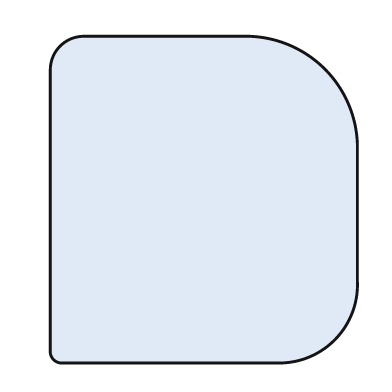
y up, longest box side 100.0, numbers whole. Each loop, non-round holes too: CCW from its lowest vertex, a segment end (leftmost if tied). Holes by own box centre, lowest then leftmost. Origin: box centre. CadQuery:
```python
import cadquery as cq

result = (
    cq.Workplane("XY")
    .moveTo(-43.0, -50.0)
    .lineTo(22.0, -50.0)
    .threePointArc((40.0, -43.0), (47.0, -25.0))
    .lineTo(47.0, 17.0)
    .threePointArc((37.0, 40.0), (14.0, 50.0))
    .lineTo(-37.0, 50.0)
    .threePointArc((-44.0, 47.0), (-47.0, 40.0))
    .lineTo(-47.0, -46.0)
    .threePointArc((-46.0, -49.0), (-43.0, -50.0))
    .close()
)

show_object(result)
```